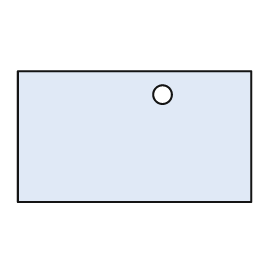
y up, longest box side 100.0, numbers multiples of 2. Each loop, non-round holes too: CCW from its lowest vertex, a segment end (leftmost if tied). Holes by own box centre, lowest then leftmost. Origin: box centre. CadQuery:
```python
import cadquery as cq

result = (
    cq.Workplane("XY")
    .moveTo(-50.0, -28.0)
    .lineTo(50.0, -28.0)
    .lineTo(50.0, 28.0)
    .lineTo(-50.0, 28.0)
    .close()
    .moveTo(12.0, 18.0)
    .circle(4.0)
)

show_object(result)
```